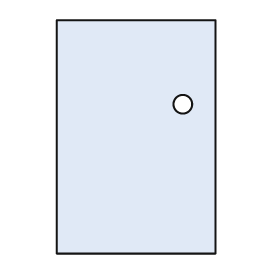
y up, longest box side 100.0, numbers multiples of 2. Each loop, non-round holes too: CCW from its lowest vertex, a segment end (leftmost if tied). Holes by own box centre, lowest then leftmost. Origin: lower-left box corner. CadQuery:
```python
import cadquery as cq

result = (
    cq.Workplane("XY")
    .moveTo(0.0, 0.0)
    .lineTo(68.0, 0.0)
    .lineTo(68.0, 100.0)
    .lineTo(0.0, 100.0)
    .close()
    .moveTo(54.0, 64.0)
    .circle(4.0)
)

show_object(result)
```